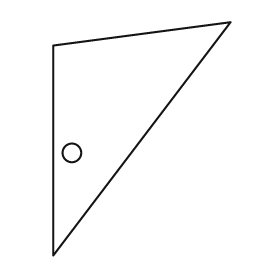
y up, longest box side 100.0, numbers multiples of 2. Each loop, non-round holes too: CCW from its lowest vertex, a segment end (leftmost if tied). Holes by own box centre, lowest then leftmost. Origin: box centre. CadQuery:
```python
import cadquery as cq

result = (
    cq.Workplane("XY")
    .moveTo(-38.0, -50.0)
    .lineTo(38.0, 50.0)
    .lineTo(-38.0, 40.0)
    .close()
    .moveTo(-30.0, -6.0)
    .circle(4.0)
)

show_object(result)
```